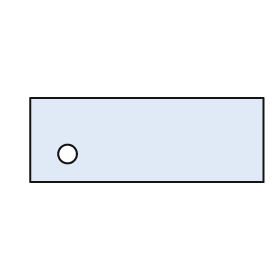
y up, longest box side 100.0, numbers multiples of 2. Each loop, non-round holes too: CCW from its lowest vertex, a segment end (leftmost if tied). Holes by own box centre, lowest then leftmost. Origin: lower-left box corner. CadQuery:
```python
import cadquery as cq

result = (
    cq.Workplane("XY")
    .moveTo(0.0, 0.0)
    .lineTo(100.0, 0.0)
    .lineTo(100.0, 36.0)
    .lineTo(0.0, 36.0)
    .close()
    .moveTo(16.0, 12.0)
    .circle(4.0)
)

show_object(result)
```